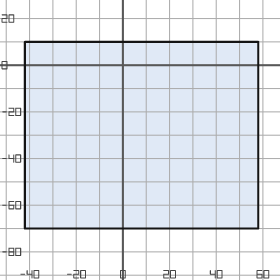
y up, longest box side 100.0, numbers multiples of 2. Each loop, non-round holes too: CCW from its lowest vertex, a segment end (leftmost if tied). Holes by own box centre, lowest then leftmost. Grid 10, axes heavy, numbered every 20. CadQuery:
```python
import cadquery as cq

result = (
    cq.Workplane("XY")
    .moveTo(-42.0, -70.0)
    .lineTo(58.0, -70.0)
    .lineTo(58.0, 10.0)
    .lineTo(-42.0, 10.0)
    .close()
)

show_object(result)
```